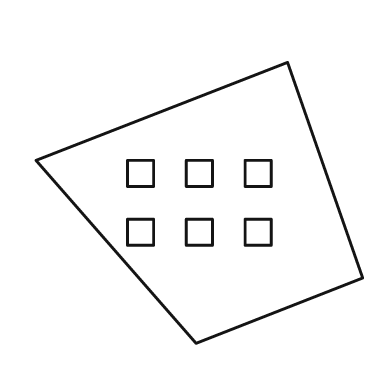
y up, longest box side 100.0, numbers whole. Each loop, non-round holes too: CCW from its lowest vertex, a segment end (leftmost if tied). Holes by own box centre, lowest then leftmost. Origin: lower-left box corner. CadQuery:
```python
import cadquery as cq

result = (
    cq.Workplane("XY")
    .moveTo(49.0, 0.0)
    .lineTo(100.0, 20.0)
    .lineTo(77.0, 86.0)
    .lineTo(0.0, 56.0)
    .close()
    .moveTo(28.0, 30.0)
    .lineTo(36.0, 30.0)
    .lineTo(36.0, 38.0)
    .lineTo(28.0, 38.0)
    .close()
    .moveTo(46.0, 30.0)
    .lineTo(54.0, 30.0)
    .lineTo(54.0, 38.0)
    .lineTo(46.0, 38.0)
    .close()
    .moveTo(64.0, 30.0)
    .lineTo(72.0, 30.0)
    .lineTo(72.0, 38.0)
    .lineTo(64.0, 38.0)
    .close()
    .moveTo(28.0, 48.0)
    .lineTo(36.0, 48.0)
    .lineTo(36.0, 56.0)
    .lineTo(28.0, 56.0)
    .close()
    .moveTo(46.0, 48.0)
    .lineTo(54.0, 48.0)
    .lineTo(54.0, 56.0)
    .lineTo(46.0, 56.0)
    .close()
    .moveTo(64.0, 48.0)
    .lineTo(72.0, 48.0)
    .lineTo(72.0, 56.0)
    .lineTo(64.0, 56.0)
    .close()
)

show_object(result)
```